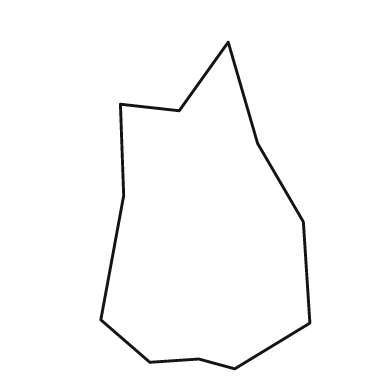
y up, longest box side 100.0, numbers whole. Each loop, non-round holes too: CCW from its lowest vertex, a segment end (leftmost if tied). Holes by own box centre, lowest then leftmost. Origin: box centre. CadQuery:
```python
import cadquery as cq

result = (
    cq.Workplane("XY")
    .moveTo(9.0, -50.0)
    .lineTo(32.0, -36.0)
    .lineTo(30.0, -5.0)
    .lineTo(16.0, 19.0)
    .lineTo(7.0, 50.0)
    .lineTo(-8.0, 29.0)
    .lineTo(-26.0, 31.0)
    .lineTo(-25.0, 3.0)
    .lineTo(-32.0, -35.0)
    .lineTo(-17.0, -48.0)
    .lineTo(-2.0, -47.0)
    .close()
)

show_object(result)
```